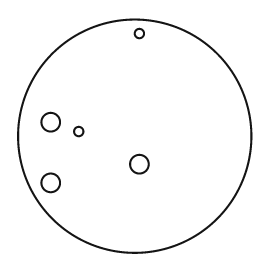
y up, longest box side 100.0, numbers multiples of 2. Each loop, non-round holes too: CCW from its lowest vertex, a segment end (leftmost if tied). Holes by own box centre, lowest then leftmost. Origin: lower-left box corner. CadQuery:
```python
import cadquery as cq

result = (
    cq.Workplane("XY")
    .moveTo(50.0, 50.0)
    .circle(50.0)
    .moveTo(14.0, 30.0)
    .circle(4.0)
    .moveTo(52.0, 38.0)
    .circle(4.0)
    .moveTo(26.0, 52.0)
    .circle(2.0)
    .moveTo(14.0, 56.0)
    .circle(4.0)
    .moveTo(52.0, 94.0)
    .circle(2.0)
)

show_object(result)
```